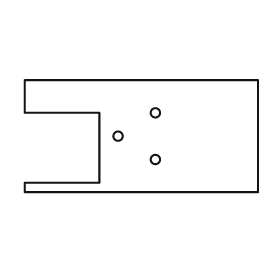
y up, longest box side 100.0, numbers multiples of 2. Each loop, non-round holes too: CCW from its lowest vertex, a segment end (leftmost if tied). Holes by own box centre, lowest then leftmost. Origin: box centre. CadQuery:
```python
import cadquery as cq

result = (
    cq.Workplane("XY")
    .moveTo(-50.0, -24.0)
    .lineTo(50.0, -24.0)
    .lineTo(50.0, 24.0)
    .lineTo(-50.0, 24.0)
    .lineTo(-50.0, 10.0)
    .lineTo(-18.0, 10.0)
    .lineTo(-18.0, -20.0)
    .lineTo(-50.0, -20.0)
    .close()
    .moveTo(6.0, -10.0)
    .circle(2.0)
    .moveTo(-10.0, 0.0)
    .circle(2.0)
    .moveTo(6.0, 10.0)
    .circle(2.0)
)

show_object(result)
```